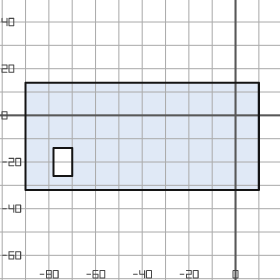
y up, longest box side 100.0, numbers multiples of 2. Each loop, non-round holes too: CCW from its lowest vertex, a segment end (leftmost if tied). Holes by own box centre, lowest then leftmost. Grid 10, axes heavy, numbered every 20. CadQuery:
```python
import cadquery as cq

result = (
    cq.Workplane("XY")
    .moveTo(-90.0, -32.0)
    .lineTo(10.0, -32.0)
    .lineTo(10.0, 14.0)
    .lineTo(-90.0, 14.0)
    .close()
    .moveTo(-78.0, -26.0)
    .lineTo(-70.0, -26.0)
    .lineTo(-70.0, -14.0)
    .lineTo(-78.0, -14.0)
    .close()
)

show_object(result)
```